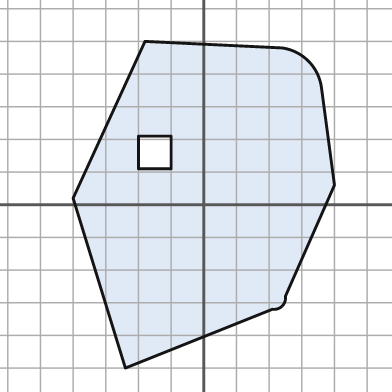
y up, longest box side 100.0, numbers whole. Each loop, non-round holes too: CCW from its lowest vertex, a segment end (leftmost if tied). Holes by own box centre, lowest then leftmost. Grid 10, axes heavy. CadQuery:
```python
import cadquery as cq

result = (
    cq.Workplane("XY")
    .moveTo(-24.0, -50.0)
    .lineTo(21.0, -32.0)
    .threePointArc((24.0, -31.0), (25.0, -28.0))
    .lineTo(40.0, 6.0)
    .lineTo(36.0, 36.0)
    .threePointArc((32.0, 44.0), (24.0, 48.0))
    .lineTo(-18.0, 50.0)
    .lineTo(-40.0, 2.0)
    .close()
    .moveTo(-20.0, 11.0)
    .lineTo(-10.0, 11.0)
    .lineTo(-10.0, 21.0)
    .lineTo(-20.0, 21.0)
    .close()
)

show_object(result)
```